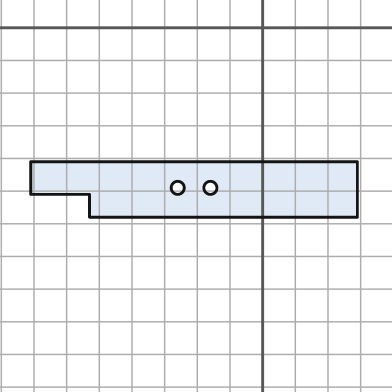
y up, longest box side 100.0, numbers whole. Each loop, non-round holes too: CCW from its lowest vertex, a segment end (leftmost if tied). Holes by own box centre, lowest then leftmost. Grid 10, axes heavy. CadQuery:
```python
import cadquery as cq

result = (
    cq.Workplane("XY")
    .moveTo(-53.0, -58.0)
    .lineTo(29.0, -58.0)
    .lineTo(29.0, -41.0)
    .lineTo(-71.0, -41.0)
    .lineTo(-71.0, -51.0)
    .lineTo(-53.0, -51.0)
    .close()
    .moveTo(-26.0, -49.0)
    .circle(2.0)
    .moveTo(-16.0, -49.0)
    .circle(2.0)
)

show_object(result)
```